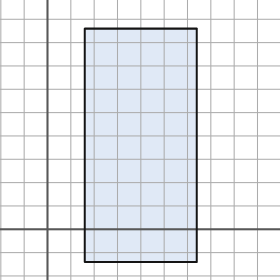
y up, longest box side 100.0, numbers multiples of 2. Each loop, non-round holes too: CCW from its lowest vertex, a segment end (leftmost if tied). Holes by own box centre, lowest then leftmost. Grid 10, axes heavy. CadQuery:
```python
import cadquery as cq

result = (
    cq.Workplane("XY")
    .moveTo(16.0, -14.0)
    .lineTo(64.0, -14.0)
    .lineTo(64.0, 86.0)
    .lineTo(16.0, 86.0)
    .close()
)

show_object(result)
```